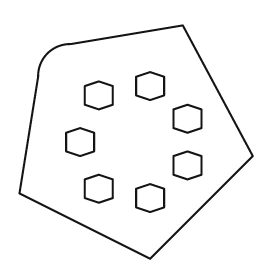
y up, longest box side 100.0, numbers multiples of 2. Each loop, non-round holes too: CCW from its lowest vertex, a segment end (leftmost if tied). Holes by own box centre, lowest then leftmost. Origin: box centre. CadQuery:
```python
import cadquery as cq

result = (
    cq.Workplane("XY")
    .moveTo(6.0, -50.0)
    .lineTo(50.0, -6.0)
    .lineTo(20.0, 50.0)
    .lineTo(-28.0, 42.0)
    .threePointArc((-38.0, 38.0), (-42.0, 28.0))
    .lineTo(-50.0, -22.0)
    .close()
    .moveTo(6.0, -30.0)
    .lineTo(12.0, -28.0)
    .lineTo(12.0, -20.0)
    .lineTo(6.0, -18.0)
    .lineTo(0.0, -20.0)
    .lineTo(0.0, -28.0)
    .close()
    .moveTo(-16.0, -26.0)
    .lineTo(-10.0, -24.0)
    .lineTo(-10.0, -16.0)
    .lineTo(-16.0, -14.0)
    .lineTo(-22.0, -16.0)
    .lineTo(-22.0, -24.0)
    .close()
    .moveTo(22.0, -16.0)
    .lineTo(28.0, -14.0)
    .lineTo(28.0, -6.0)
    .lineTo(22.0, -4.0)
    .lineTo(16.0, -6.0)
    .lineTo(16.0, -14.0)
    .close()
    .moveTo(-24.0, -6.0)
    .lineTo(-18.0, -4.0)
    .lineTo(-18.0, 4.0)
    .lineTo(-24.0, 6.0)
    .lineTo(-30.0, 4.0)
    .lineTo(-30.0, -4.0)
    .close()
    .moveTo(22.0, 4.0)
    .lineTo(28.0, 6.0)
    .lineTo(28.0, 14.0)
    .lineTo(22.0, 16.0)
    .lineTo(16.0, 14.0)
    .lineTo(16.0, 6.0)
    .close()
    .moveTo(-16.0, 14.0)
    .lineTo(-10.0, 16.0)
    .lineTo(-10.0, 24.0)
    .lineTo(-16.0, 26.0)
    .lineTo(-22.0, 24.0)
    .lineTo(-22.0, 16.0)
    .close()
    .moveTo(6.0, 18.0)
    .lineTo(12.0, 20.0)
    .lineTo(12.0, 28.0)
    .lineTo(6.0, 30.0)
    .lineTo(0.0, 28.0)
    .lineTo(0.0, 20.0)
    .close()
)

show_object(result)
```